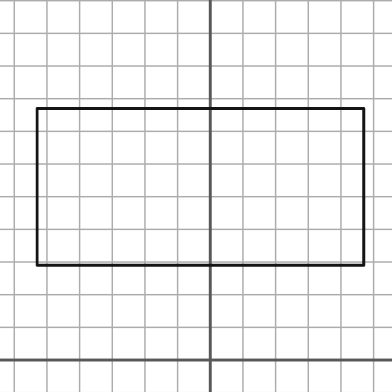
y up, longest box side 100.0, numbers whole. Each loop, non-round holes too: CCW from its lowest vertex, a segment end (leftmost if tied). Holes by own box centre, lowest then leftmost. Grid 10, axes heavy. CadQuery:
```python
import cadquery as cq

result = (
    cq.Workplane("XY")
    .moveTo(-53.0, 29.0)
    .lineTo(47.0, 29.0)
    .lineTo(47.0, 77.0)
    .lineTo(-53.0, 77.0)
    .close()
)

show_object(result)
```